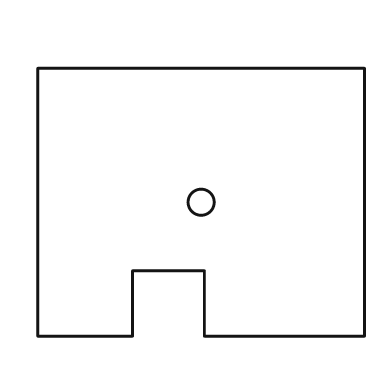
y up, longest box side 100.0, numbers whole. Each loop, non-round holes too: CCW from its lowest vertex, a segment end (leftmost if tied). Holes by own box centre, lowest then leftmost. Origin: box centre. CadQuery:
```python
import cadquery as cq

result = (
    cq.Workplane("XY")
    .moveTo(-50.0, -41.0)
    .lineTo(-21.0, -41.0)
    .lineTo(-21.0, -21.0)
    .lineTo(1.0, -21.0)
    .lineTo(1.0, -41.0)
    .lineTo(50.0, -41.0)
    .lineTo(50.0, 41.0)
    .lineTo(-50.0, 41.0)
    .close()
    .moveTo(0.0, 0.0)
    .circle(4.0)
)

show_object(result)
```